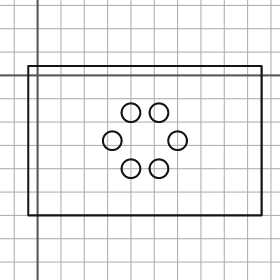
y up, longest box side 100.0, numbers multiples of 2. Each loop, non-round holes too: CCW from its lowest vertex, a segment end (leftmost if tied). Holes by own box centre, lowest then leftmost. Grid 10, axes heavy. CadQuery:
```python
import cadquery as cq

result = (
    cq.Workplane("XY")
    .moveTo(-4.0, -60.0)
    .lineTo(96.0, -60.0)
    .lineTo(96.0, 4.0)
    .lineTo(-4.0, 4.0)
    .close()
    .moveTo(40.0, -40.0)
    .circle(4.0)
    .moveTo(52.0, -40.0)
    .circle(4.0)
    .moveTo(32.0, -28.0)
    .circle(4.0)
    .moveTo(60.0, -28.0)
    .circle(4.0)
    .moveTo(40.0, -16.0)
    .circle(4.0)
    .moveTo(52.0, -16.0)
    .circle(4.0)
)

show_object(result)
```